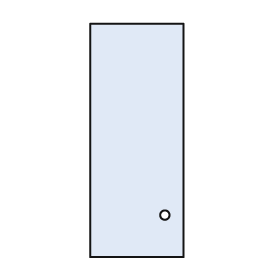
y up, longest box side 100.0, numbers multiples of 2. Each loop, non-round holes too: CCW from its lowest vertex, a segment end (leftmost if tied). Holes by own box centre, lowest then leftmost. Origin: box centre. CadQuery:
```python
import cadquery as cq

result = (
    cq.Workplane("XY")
    .moveTo(-20.0, -50.0)
    .lineTo(20.0, -50.0)
    .lineTo(20.0, 50.0)
    .lineTo(-20.0, 50.0)
    .close()
    .moveTo(12.0, -32.0)
    .circle(2.0)
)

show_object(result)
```